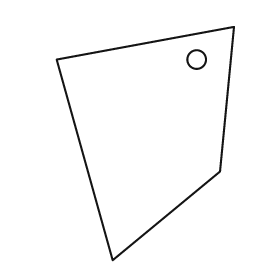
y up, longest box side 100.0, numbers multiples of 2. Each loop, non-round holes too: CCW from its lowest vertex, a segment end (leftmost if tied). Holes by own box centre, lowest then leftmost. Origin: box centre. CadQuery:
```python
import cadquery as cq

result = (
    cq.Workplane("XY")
    .moveTo(-14.0, -50.0)
    .lineTo(32.0, -12.0)
    .lineTo(38.0, 50.0)
    .lineTo(-38.0, 36.0)
    .close()
    .moveTo(22.0, 36.0)
    .circle(4.0)
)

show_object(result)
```